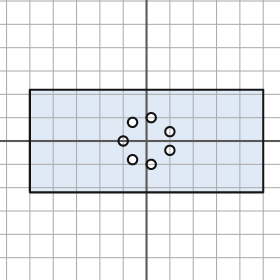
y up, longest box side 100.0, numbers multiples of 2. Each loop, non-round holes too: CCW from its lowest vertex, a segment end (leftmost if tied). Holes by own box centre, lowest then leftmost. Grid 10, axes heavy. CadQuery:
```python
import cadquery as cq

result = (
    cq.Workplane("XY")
    .moveTo(-50.0, -22.0)
    .lineTo(50.0, -22.0)
    .lineTo(50.0, 22.0)
    .lineTo(-50.0, 22.0)
    .close()
    .moveTo(2.0, -10.0)
    .circle(2.0)
    .moveTo(-6.0, -8.0)
    .circle(2.0)
    .moveTo(10.0, -4.0)
    .circle(2.0)
    .moveTo(-10.0, 0.0)
    .circle(2.0)
    .moveTo(10.0, 4.0)
    .circle(2.0)
    .moveTo(-6.0, 8.0)
    .circle(2.0)
    .moveTo(2.0, 10.0)
    .circle(2.0)
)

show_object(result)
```